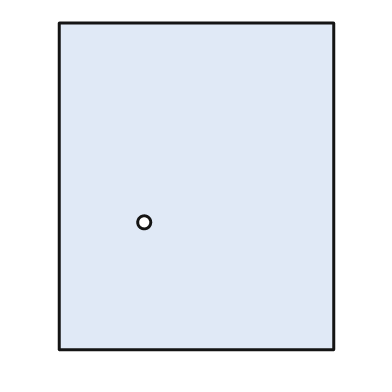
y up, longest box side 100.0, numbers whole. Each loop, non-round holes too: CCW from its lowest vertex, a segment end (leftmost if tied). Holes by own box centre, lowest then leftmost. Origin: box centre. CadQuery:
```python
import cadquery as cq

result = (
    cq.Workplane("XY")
    .moveTo(-42.0, -50.0)
    .lineTo(42.0, -50.0)
    .lineTo(42.0, 50.0)
    .lineTo(-42.0, 50.0)
    .close()
    .moveTo(-16.0, -11.0)
    .circle(2.0)
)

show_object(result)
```